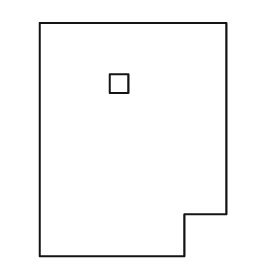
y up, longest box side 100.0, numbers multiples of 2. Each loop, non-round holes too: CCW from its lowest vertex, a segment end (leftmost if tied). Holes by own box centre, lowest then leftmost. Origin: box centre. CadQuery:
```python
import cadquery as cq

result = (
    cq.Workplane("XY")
    .moveTo(-40.0, -50.0)
    .lineTo(22.0, -50.0)
    .lineTo(22.0, -32.0)
    .lineTo(40.0, -32.0)
    .lineTo(40.0, 50.0)
    .lineTo(-40.0, 50.0)
    .close()
    .moveTo(-10.0, 20.0)
    .lineTo(-2.0, 20.0)
    .lineTo(-2.0, 28.0)
    .lineTo(-10.0, 28.0)
    .close()
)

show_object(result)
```